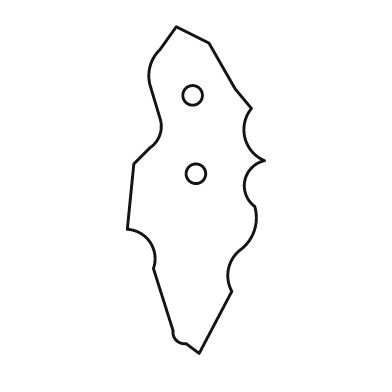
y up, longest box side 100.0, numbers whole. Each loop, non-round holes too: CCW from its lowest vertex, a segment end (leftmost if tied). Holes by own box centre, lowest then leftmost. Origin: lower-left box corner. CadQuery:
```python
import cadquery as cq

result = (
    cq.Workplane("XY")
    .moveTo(22.0, 0.0)
    .lineTo(32.0, 19.0)
    .threePointArc((31.0, 26.0), (35.0, 32.0))
    .threePointArc((39.0, 38.0), (39.0, 45.0))
    .threePointArc((36.0, 53.0), (42.0, 59.0))
    .threePointArc((36.0, 66.0), (38.0, 75.0))
    .lineTo(33.0, 81.0)
    .lineTo(25.0, 95.0)
    .lineTo(15.0, 100.0)
    .lineTo(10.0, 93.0)
    .threePointArc((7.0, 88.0), (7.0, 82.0))
    .lineTo(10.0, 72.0)
    .threePointArc((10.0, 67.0), (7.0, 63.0))
    .lineTo(2.0, 58.0)
    .lineTo(0.0, 38.0)
    .threePointArc((7.0, 34.0), (8.0, 26.0))
    .lineTo(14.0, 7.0)
    .threePointArc((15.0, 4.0), (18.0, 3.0))
    .close()
    .moveTo(21.0, 55.0)
    .circle(3.0)
    .moveTo(20.0, 79.0)
    .circle(3.0)
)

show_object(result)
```